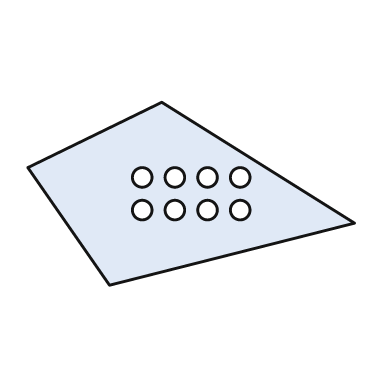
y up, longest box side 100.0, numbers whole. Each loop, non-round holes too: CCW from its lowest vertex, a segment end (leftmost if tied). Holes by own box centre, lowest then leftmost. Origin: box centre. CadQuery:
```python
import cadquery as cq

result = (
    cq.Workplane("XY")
    .moveTo(-25.0, -28.0)
    .lineTo(50.0, -9.0)
    .lineTo(-9.0, 28.0)
    .lineTo(-50.0, 8.0)
    .close()
    .moveTo(-15.0, -5.0)
    .circle(3.0)
    .moveTo(-5.0, -5.0)
    .circle(3.0)
    .moveTo(5.0, -5.0)
    .circle(3.0)
    .moveTo(15.0, -5.0)
    .circle(3.0)
    .moveTo(-15.0, 5.0)
    .circle(3.0)
    .moveTo(-5.0, 5.0)
    .circle(3.0)
    .moveTo(5.0, 5.0)
    .circle(3.0)
    .moveTo(15.0, 5.0)
    .circle(3.0)
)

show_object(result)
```